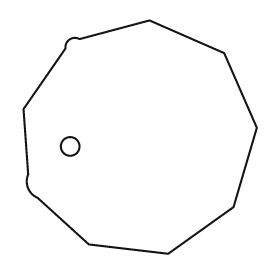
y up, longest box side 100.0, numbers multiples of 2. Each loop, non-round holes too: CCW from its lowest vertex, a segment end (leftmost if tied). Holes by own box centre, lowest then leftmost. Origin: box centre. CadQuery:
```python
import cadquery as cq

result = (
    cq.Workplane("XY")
    .moveTo(12.0, -50.0)
    .lineTo(40.0, -30.0)
    .lineTo(50.0, 4.0)
    .lineTo(36.0, 36.0)
    .lineTo(4.0, 50.0)
    .lineTo(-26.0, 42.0)
    .threePointArc((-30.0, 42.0), (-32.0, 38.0))
    .lineTo(-50.0, 12.0)
    .lineTo(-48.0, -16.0)
    .threePointArc((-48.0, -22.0), (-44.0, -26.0))
    .lineTo(-22.0, -46.0)
    .close()
    .moveTo(-30.0, -4.0)
    .circle(4.0)
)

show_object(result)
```